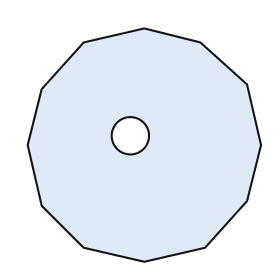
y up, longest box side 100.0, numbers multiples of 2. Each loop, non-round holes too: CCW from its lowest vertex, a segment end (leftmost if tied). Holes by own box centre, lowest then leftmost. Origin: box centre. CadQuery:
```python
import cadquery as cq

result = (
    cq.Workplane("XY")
    .moveTo(0.0, -50.0)
    .lineTo(26.0, -44.0)
    .lineTo(44.0, -24.0)
    .lineTo(50.0, 0.0)
    .lineTo(44.0, 26.0)
    .lineTo(24.0, 44.0)
    .lineTo(0.0, 50.0)
    .lineTo(-26.0, 44.0)
    .lineTo(-44.0, 24.0)
    .lineTo(-50.0, 0.0)
    .lineTo(-44.0, -26.0)
    .lineTo(-26.0, -44.0)
    .close()
    .moveTo(-6.0, 4.0)
    .circle(8.0)
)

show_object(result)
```